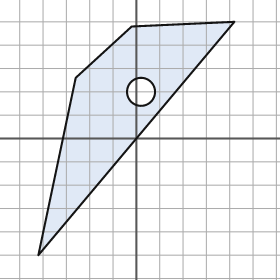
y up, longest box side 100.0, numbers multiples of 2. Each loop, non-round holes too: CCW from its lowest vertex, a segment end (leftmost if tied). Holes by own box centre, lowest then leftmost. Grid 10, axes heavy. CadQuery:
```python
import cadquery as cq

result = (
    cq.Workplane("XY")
    .moveTo(-42.0, -50.0)
    .lineTo(42.0, 50.0)
    .lineTo(-2.0, 48.0)
    .lineTo(-26.0, 26.0)
    .close()
    .moveTo(2.0, 20.0)
    .circle(6.0)
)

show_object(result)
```